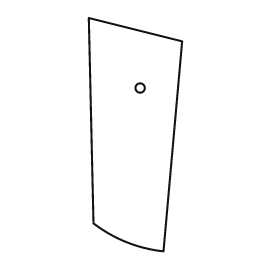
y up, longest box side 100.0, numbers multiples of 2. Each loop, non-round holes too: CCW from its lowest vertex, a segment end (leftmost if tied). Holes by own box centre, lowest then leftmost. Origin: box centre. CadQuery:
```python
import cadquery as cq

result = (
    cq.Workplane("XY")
    .moveTo(12.0, -50.0)
    .lineTo(20.0, 40.0)
    .lineTo(-20.0, 50.0)
    .lineTo(-18.0, -38.0)
    .threePointArc((-4.0, -46.0), (12.0, -50.0))
    .close()
    .moveTo(2.0, 20.0)
    .circle(2.0)
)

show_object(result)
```